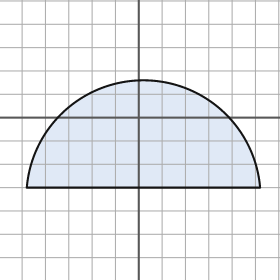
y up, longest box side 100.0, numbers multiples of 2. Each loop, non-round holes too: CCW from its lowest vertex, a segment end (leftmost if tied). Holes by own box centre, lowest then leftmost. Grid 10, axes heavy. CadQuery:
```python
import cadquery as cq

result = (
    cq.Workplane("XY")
    .moveTo(-48.0, -30.0)
    .lineTo(52.0, -30.0)
    .threePointArc((2.0, 16.0), (-48.0, -30.0))
    .close()
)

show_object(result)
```